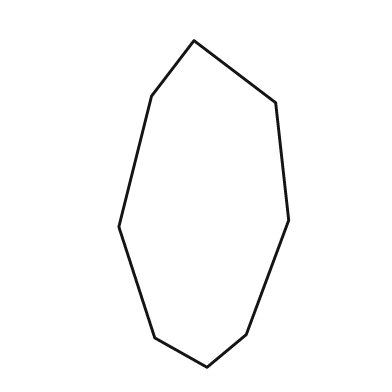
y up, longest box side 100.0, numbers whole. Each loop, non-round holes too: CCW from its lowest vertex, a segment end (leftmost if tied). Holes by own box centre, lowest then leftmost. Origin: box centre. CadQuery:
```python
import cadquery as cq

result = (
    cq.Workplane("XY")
    .moveTo(1.0, -50.0)
    .lineTo(13.0, -40.0)
    .lineTo(26.0, -5.0)
    .lineTo(22.0, 31.0)
    .lineTo(-3.0, 50.0)
    .lineTo(-16.0, 33.0)
    .lineTo(-26.0, -7.0)
    .lineTo(-15.0, -41.0)
    .close()
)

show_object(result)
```